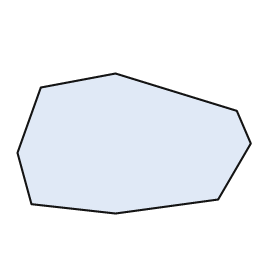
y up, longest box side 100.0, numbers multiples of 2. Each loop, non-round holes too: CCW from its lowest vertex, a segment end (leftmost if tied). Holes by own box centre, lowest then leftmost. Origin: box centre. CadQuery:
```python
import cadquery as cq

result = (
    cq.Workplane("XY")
    .moveTo(-8.0, -30.0)
    .lineTo(36.0, -24.0)
    .lineTo(50.0, 0.0)
    .lineTo(44.0, 14.0)
    .lineTo(-8.0, 30.0)
    .lineTo(-40.0, 24.0)
    .lineTo(-50.0, -4.0)
    .lineTo(-44.0, -26.0)
    .close()
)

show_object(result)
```